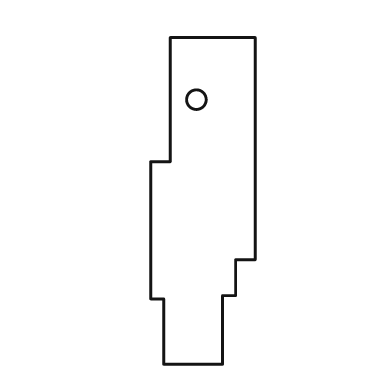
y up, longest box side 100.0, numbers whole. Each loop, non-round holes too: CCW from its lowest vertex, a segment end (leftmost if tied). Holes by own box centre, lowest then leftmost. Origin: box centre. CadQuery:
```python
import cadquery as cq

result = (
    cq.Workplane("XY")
    .moveTo(-12.0, -50.0)
    .lineTo(6.0, -50.0)
    .lineTo(6.0, -29.0)
    .lineTo(10.0, -29.0)
    .lineTo(10.0, -18.0)
    .lineTo(16.0, -18.0)
    .lineTo(16.0, 50.0)
    .lineTo(-10.0, 50.0)
    .lineTo(-10.0, 12.0)
    .lineTo(-16.0, 12.0)
    .lineTo(-16.0, -30.0)
    .lineTo(-12.0, -30.0)
    .close()
    .moveTo(-2.0, 31.0)
    .circle(3.0)
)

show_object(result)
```